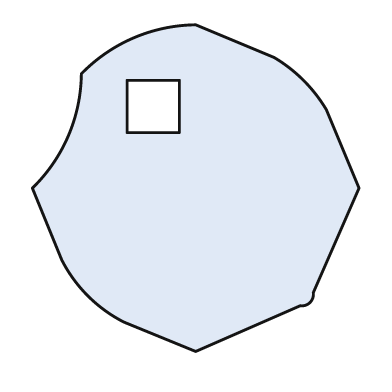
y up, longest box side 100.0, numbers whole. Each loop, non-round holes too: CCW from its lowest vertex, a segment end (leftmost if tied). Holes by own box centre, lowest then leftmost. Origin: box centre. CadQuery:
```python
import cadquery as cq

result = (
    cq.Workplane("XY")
    .moveTo(0.0, -50.0)
    .lineTo(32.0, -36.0)
    .threePointArc((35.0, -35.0), (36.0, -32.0))
    .lineTo(50.0, 0.0)
    .lineTo(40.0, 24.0)
    .threePointArc((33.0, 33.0), (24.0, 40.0))
    .lineTo(0.0, 50.0)
    .threePointArc((-19.0, 46.0), (-35.0, 35.0))
    .threePointArc((-39.0, 16.0), (-50.0, 0.0))
    .lineTo(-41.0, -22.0)
    .threePointArc((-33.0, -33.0), (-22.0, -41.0))
    .close()
    .moveTo(-21.0, 17.0)
    .lineTo(-5.0, 17.0)
    .lineTo(-5.0, 33.0)
    .lineTo(-21.0, 33.0)
    .close()
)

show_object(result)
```